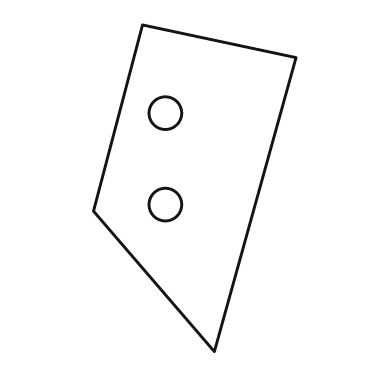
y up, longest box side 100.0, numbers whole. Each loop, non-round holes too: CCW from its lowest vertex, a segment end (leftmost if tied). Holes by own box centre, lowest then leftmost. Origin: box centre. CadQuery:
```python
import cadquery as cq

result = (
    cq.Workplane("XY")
    .moveTo(6.0, -50.0)
    .lineTo(31.0, 40.0)
    .lineTo(-16.0, 50.0)
    .lineTo(-31.0, -7.0)
    .close()
    .moveTo(-9.0, -5.0)
    .circle(5.0)
    .moveTo(-9.0, 23.0)
    .circle(5.0)
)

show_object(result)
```